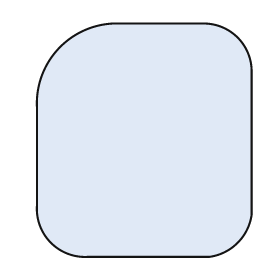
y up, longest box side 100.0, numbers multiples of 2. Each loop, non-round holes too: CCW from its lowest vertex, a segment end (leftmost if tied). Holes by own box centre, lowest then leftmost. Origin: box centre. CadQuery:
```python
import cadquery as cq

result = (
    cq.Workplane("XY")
    .moveTo(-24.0, -50.0)
    .lineTo(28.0, -50.0)
    .threePointArc((40.0, -44.0), (46.0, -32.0))
    .lineTo(46.0, 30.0)
    .threePointArc((40.0, 44.0), (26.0, 50.0))
    .lineTo(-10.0, 50.0)
    .threePointArc((-36.0, 40.0), (-46.0, 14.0))
    .lineTo(-46.0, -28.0)
    .threePointArc((-40.0, -44.0), (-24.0, -50.0))
    .close()
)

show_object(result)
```